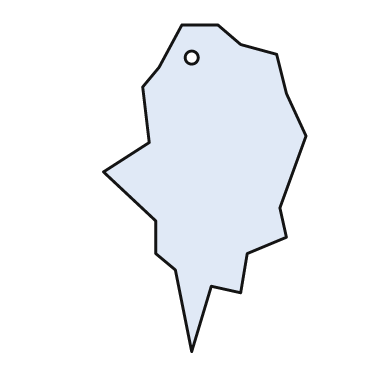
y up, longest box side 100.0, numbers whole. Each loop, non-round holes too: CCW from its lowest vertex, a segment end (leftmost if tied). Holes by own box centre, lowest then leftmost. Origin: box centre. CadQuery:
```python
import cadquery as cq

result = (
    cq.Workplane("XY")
    .moveTo(-4.0, -50.0)
    .lineTo(2.0, -30.0)
    .lineTo(11.0, -32.0)
    .lineTo(13.0, -20.0)
    .lineTo(25.0, -15.0)
    .lineTo(23.0, -6.0)
    .lineTo(31.0, 16.0)
    .lineTo(25.0, 29.0)
    .lineTo(22.0, 41.0)
    .lineTo(11.0, 44.0)
    .lineTo(4.0, 50.0)
    .lineTo(-7.0, 50.0)
    .lineTo(-14.0, 37.0)
    .lineTo(-19.0, 31.0)
    .lineTo(-17.0, 14.0)
    .lineTo(-31.0, 5.0)
    .lineTo(-15.0, -10.0)
    .lineTo(-15.0, -20.0)
    .lineTo(-9.0, -25.0)
    .close()
    .moveTo(-4.0, 40.0)
    .circle(2.0)
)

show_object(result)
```